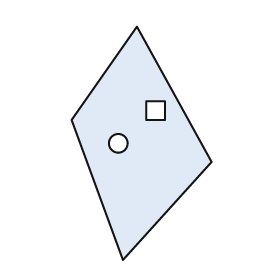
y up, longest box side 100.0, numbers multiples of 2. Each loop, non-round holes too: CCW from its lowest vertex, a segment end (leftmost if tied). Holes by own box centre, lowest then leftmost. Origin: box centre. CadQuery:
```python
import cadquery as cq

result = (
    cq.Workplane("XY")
    .moveTo(-8.0, -50.0)
    .lineTo(30.0, -8.0)
    .lineTo(-2.0, 50.0)
    .lineTo(-30.0, 10.0)
    .close()
    .moveTo(-10.0, 0.0)
    .circle(4.0)
    .moveTo(2.0, 10.0)
    .lineTo(10.0, 10.0)
    .lineTo(10.0, 18.0)
    .lineTo(2.0, 18.0)
    .close()
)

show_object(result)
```